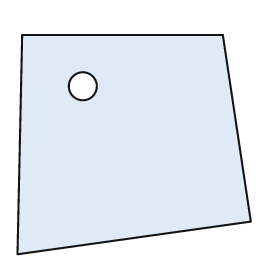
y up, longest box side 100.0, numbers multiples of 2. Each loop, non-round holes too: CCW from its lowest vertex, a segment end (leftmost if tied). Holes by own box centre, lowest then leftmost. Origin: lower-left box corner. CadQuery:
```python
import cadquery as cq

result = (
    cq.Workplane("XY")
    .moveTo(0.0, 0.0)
    .lineTo(100.0, 14.0)
    .lineTo(88.0, 94.0)
    .lineTo(2.0, 94.0)
    .close()
    .moveTo(28.0, 72.0)
    .circle(6.0)
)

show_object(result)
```